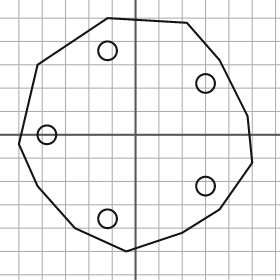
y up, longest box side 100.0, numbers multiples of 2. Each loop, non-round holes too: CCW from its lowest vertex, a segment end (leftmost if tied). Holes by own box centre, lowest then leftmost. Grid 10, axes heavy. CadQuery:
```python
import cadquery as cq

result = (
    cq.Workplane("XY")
    .moveTo(-4.0, -50.0)
    .lineTo(20.0, -42.0)
    .lineTo(36.0, -32.0)
    .lineTo(50.0, -12.0)
    .lineTo(48.0, 8.0)
    .lineTo(36.0, 32.0)
    .lineTo(22.0, 48.0)
    .lineTo(-12.0, 50.0)
    .lineTo(-42.0, 30.0)
    .lineTo(-50.0, -4.0)
    .lineTo(-42.0, -22.0)
    .lineTo(-26.0, -40.0)
    .close()
    .moveTo(-12.0, -36.0)
    .circle(4.0)
    .moveTo(30.0, -22.0)
    .circle(4.0)
    .moveTo(-38.0, 0.0)
    .circle(4.0)
    .moveTo(30.0, 22.0)
    .circle(4.0)
    .moveTo(-12.0, 36.0)
    .circle(4.0)
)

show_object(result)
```